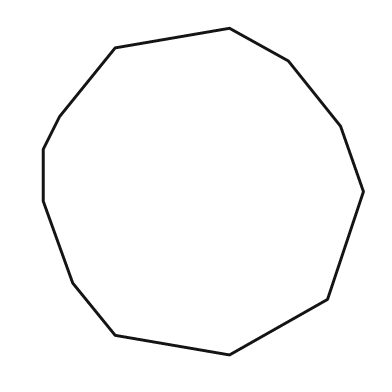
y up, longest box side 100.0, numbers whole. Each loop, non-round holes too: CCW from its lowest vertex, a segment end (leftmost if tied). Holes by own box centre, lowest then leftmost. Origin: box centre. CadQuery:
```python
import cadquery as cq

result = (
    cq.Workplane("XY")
    .moveTo(8.0, -50.0)
    .lineTo(38.0, -33.0)
    .lineTo(49.0, 0.0)
    .lineTo(42.0, 20.0)
    .lineTo(26.0, 40.0)
    .lineTo(8.0, 50.0)
    .lineTo(-27.0, 44.0)
    .lineTo(-44.0, 23.0)
    .lineTo(-49.0, 13.0)
    .lineTo(-49.0, -3.0)
    .lineTo(-40.0, -28.0)
    .lineTo(-27.0, -44.0)
    .close()
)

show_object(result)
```